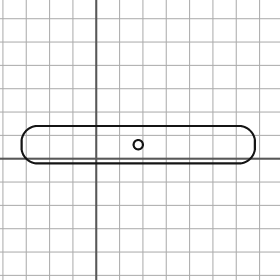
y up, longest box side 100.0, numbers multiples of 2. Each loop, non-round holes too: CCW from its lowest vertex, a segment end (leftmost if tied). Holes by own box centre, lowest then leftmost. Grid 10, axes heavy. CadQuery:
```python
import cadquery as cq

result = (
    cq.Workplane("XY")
    .moveTo(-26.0, -2.0)
    .lineTo(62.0, -2.0)
    .threePointArc((66.0, 0.0), (68.0, 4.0))
    .lineTo(68.0, 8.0)
    .threePointArc((66.0, 12.0), (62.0, 14.0))
    .lineTo(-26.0, 14.0)
    .threePointArc((-30.0, 12.0), (-32.0, 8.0))
    .lineTo(-32.0, 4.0)
    .threePointArc((-30.0, 0.0), (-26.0, -2.0))
    .close()
    .moveTo(18.0, 6.0)
    .circle(2.0)
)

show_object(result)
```